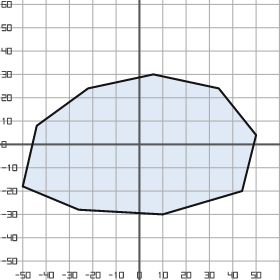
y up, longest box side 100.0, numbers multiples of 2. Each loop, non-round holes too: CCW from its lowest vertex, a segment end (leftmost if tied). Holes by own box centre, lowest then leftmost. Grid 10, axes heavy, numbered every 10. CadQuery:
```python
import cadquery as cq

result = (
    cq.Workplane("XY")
    .moveTo(10.0, -30.0)
    .lineTo(44.0, -20.0)
    .lineTo(50.0, 4.0)
    .lineTo(34.0, 24.0)
    .lineTo(6.0, 30.0)
    .lineTo(-22.0, 24.0)
    .lineTo(-44.0, 8.0)
    .lineTo(-50.0, -18.0)
    .lineTo(-26.0, -28.0)
    .close()
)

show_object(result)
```